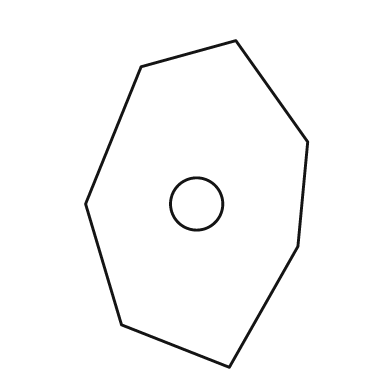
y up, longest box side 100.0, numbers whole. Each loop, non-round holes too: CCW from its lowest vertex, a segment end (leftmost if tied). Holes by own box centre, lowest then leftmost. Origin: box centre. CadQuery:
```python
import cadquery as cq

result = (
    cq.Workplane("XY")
    .moveTo(10.0, -50.0)
    .lineTo(31.0, -13.0)
    .lineTo(34.0, 19.0)
    .lineTo(12.0, 50.0)
    .lineTo(-17.0, 42.0)
    .lineTo(-34.0, 0.0)
    .lineTo(-23.0, -37.0)
    .close()
    .moveTo(0.0, 0.0)
    .circle(8.0)
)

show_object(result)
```